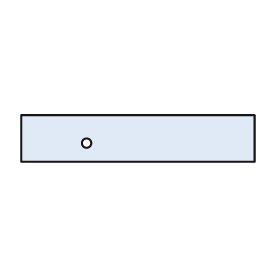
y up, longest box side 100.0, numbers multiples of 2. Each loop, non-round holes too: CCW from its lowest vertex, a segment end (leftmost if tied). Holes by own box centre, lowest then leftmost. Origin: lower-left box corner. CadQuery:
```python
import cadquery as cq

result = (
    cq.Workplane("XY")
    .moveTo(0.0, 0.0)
    .lineTo(100.0, 0.0)
    .lineTo(100.0, 20.0)
    .lineTo(0.0, 20.0)
    .close()
    .moveTo(28.0, 8.0)
    .circle(2.0)
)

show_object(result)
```